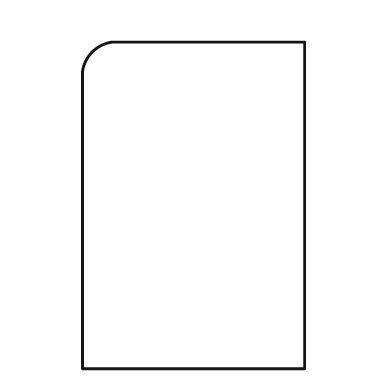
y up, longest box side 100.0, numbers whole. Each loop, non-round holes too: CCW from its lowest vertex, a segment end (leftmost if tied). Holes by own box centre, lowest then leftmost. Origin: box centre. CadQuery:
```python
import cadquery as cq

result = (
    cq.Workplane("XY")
    .moveTo(-34.0, -50.0)
    .lineTo(34.0, -50.0)
    .lineTo(34.0, 50.0)
    .lineTo(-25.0, 50.0)
    .threePointArc((-31.0, 47.0), (-34.0, 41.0))
    .close()
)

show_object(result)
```